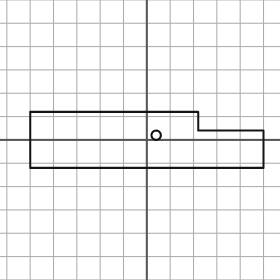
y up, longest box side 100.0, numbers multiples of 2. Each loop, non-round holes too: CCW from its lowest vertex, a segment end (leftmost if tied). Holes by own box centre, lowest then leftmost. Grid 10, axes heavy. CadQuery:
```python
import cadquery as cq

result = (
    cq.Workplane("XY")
    .moveTo(-50.0, -12.0)
    .lineTo(50.0, -12.0)
    .lineTo(50.0, 4.0)
    .lineTo(22.0, 4.0)
    .lineTo(22.0, 12.0)
    .lineTo(-50.0, 12.0)
    .close()
    .moveTo(4.0, 2.0)
    .circle(2.0)
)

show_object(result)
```